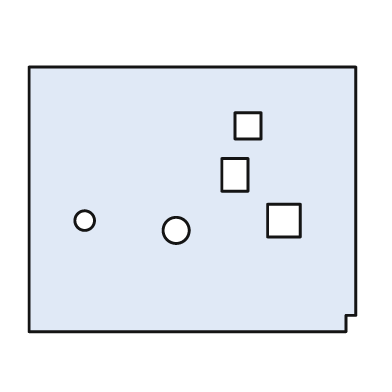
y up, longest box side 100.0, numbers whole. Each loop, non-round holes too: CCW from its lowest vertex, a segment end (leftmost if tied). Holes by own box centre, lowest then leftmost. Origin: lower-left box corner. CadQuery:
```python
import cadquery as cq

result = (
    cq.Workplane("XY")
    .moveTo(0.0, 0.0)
    .lineTo(97.0, 0.0)
    .lineTo(97.0, 5.0)
    .lineTo(100.0, 5.0)
    .lineTo(100.0, 81.0)
    .lineTo(0.0, 81.0)
    .close()
    .moveTo(45.0, 31.0)
    .circle(4.0)
    .moveTo(17.0, 34.0)
    .circle(3.0)
    .moveTo(73.0, 29.0)
    .lineTo(83.0, 29.0)
    .lineTo(83.0, 39.0)
    .lineTo(73.0, 39.0)
    .close()
    .moveTo(59.0, 43.0)
    .lineTo(67.0, 43.0)
    .lineTo(67.0, 53.0)
    .lineTo(59.0, 53.0)
    .close()
    .moveTo(63.0, 59.0)
    .lineTo(71.0, 59.0)
    .lineTo(71.0, 67.0)
    .lineTo(63.0, 67.0)
    .close()
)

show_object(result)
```